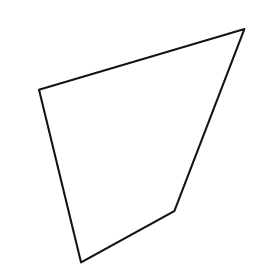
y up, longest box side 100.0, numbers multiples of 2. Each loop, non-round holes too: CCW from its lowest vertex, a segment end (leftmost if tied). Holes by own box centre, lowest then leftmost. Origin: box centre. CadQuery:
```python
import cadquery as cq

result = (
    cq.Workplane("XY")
    .moveTo(-26.0, -50.0)
    .lineTo(14.0, -28.0)
    .lineTo(44.0, 50.0)
    .lineTo(-44.0, 24.0)
    .close()
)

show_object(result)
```